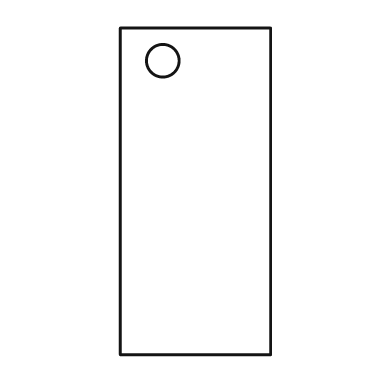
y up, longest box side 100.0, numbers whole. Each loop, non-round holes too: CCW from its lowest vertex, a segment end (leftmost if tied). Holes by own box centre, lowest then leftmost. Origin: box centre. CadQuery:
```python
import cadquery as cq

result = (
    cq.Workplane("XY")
    .moveTo(-23.0, -50.0)
    .lineTo(23.0, -50.0)
    .lineTo(23.0, 50.0)
    .lineTo(-23.0, 50.0)
    .close()
    .moveTo(-10.0, 40.0)
    .circle(5.0)
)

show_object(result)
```